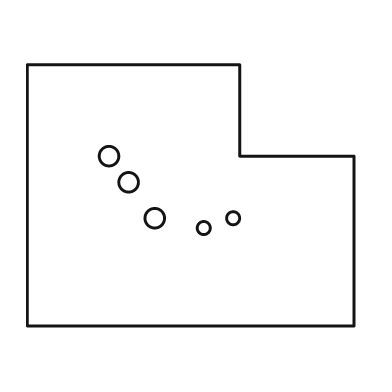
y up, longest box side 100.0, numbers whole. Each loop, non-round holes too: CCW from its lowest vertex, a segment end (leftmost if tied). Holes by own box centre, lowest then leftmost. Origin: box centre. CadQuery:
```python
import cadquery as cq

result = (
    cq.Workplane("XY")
    .moveTo(-50.0, -40.0)
    .lineTo(50.0, -40.0)
    .lineTo(50.0, 12.0)
    .lineTo(15.0, 12.0)
    .lineTo(15.0, 40.0)
    .lineTo(-50.0, 40.0)
    .close()
    .moveTo(4.0, -10.0)
    .circle(2.0)
    .moveTo(-11.0, -7.0)
    .circle(3.0)
    .moveTo(13.0, -7.0)
    .circle(2.0)
    .moveTo(-19.0, 4.0)
    .circle(3.0)
    .moveTo(-25.0, 12.0)
    .circle(3.0)
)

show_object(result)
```